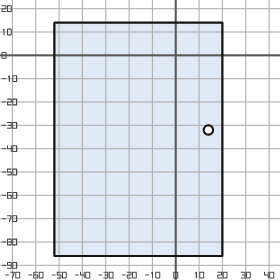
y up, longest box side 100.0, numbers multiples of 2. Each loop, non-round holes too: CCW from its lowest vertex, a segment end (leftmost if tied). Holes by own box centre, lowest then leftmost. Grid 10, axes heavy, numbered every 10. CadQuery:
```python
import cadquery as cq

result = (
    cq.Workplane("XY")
    .moveTo(-52.0, -86.0)
    .lineTo(20.0, -86.0)
    .lineTo(20.0, 14.0)
    .lineTo(-52.0, 14.0)
    .close()
    .moveTo(14.0, -32.0)
    .circle(2.0)
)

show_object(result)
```